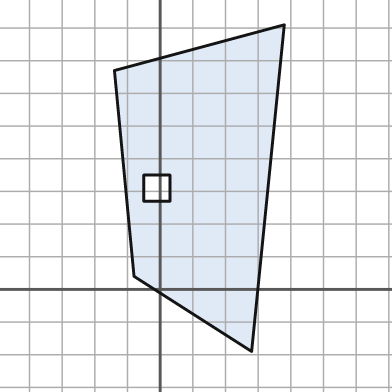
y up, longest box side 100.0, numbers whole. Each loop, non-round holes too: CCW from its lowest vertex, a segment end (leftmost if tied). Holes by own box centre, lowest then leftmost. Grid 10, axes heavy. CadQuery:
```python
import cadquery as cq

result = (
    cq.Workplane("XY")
    .moveTo(28.0, -19.0)
    .lineTo(38.0, 81.0)
    .lineTo(-14.0, 67.0)
    .lineTo(-8.0, 4.0)
    .close()
    .moveTo(-5.0, 27.0)
    .lineTo(3.0, 27.0)
    .lineTo(3.0, 35.0)
    .lineTo(-5.0, 35.0)
    .close()
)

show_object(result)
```